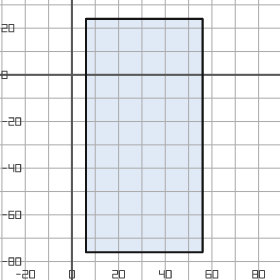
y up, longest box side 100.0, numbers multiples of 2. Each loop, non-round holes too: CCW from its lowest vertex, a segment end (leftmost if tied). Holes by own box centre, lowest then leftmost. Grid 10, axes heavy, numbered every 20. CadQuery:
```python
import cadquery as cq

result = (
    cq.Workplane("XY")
    .moveTo(6.0, -76.0)
    .lineTo(56.0, -76.0)
    .lineTo(56.0, 24.0)
    .lineTo(6.0, 24.0)
    .close()
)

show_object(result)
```